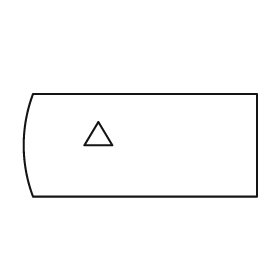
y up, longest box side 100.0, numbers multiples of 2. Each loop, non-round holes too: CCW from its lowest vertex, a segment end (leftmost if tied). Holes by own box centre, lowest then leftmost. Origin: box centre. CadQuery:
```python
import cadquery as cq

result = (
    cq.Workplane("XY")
    .moveTo(-46.0, -22.0)
    .lineTo(50.0, -22.0)
    .lineTo(50.0, 22.0)
    .lineTo(-46.0, 22.0)
    .threePointArc((-50.0, 0.0), (-46.0, -22.0))
    .close()
    .moveTo(-24.0, 0.0)
    .lineTo(-12.0, 0.0)
    .lineTo(-18.0, 10.0)
    .close()
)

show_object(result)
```